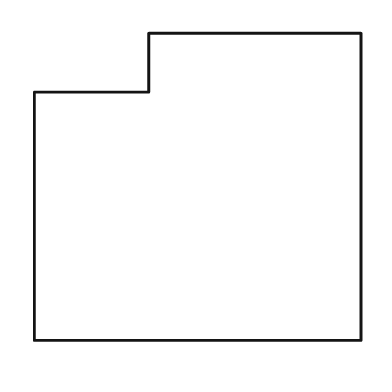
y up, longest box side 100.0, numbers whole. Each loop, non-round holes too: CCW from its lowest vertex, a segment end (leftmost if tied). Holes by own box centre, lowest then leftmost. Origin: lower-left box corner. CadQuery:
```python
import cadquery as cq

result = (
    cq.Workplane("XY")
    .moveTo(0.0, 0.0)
    .lineTo(100.0, 0.0)
    .lineTo(100.0, 94.0)
    .lineTo(35.0, 94.0)
    .lineTo(35.0, 76.0)
    .lineTo(0.0, 76.0)
    .close()
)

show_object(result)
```